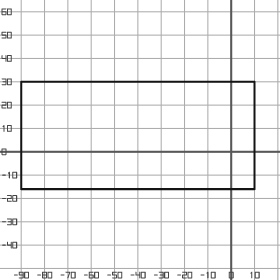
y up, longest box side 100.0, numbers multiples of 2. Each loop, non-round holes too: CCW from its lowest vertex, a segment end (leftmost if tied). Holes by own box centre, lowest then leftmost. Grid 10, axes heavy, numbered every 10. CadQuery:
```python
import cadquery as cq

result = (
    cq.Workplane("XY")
    .moveTo(-90.0, -16.0)
    .lineTo(10.0, -16.0)
    .lineTo(10.0, 30.0)
    .lineTo(-90.0, 30.0)
    .close()
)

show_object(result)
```